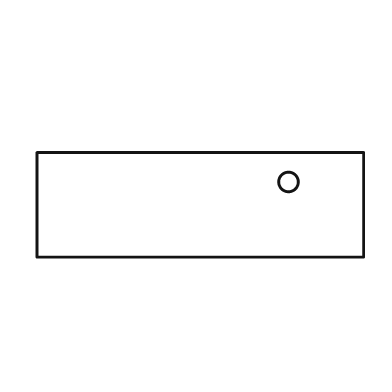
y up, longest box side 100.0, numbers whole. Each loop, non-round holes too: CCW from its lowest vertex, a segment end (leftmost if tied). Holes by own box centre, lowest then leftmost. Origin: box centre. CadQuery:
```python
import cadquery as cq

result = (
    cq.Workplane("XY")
    .moveTo(-50.0, -16.0)
    .lineTo(50.0, -16.0)
    .lineTo(50.0, 16.0)
    .lineTo(-50.0, 16.0)
    .close()
    .moveTo(27.0, 7.0)
    .circle(3.0)
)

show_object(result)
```